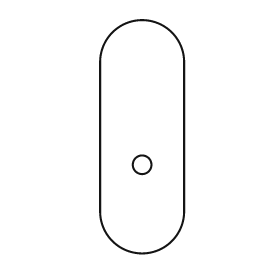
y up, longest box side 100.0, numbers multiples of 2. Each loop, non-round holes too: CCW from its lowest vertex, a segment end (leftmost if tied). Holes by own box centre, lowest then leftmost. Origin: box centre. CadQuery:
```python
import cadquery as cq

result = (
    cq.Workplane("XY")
    .moveTo(-18.0, -32.0)
    .threePointArc((0.0, -50.0), (18.0, -32.0))
    .lineTo(18.0, 32.0)
    .threePointArc((0.0, 50.0), (-18.0, 32.0))
    .close()
    .moveTo(0.0, -12.0)
    .circle(4.0)
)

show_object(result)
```